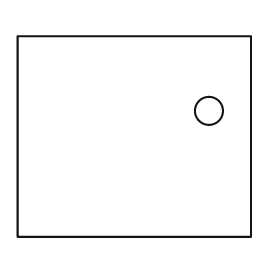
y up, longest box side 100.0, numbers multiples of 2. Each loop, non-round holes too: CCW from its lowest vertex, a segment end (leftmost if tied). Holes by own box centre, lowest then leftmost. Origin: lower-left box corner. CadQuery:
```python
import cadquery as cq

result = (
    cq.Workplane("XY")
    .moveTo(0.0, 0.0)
    .lineTo(100.0, 0.0)
    .lineTo(100.0, 86.0)
    .lineTo(0.0, 86.0)
    .close()
    .moveTo(82.0, 54.0)
    .circle(6.0)
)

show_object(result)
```